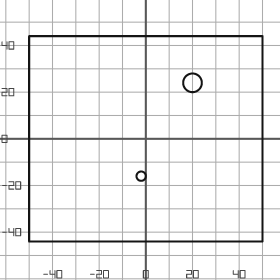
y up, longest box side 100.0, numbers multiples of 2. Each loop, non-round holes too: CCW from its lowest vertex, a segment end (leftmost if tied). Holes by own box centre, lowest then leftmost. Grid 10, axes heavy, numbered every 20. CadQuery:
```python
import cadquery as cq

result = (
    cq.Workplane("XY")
    .moveTo(-50.0, -44.0)
    .lineTo(50.0, -44.0)
    .lineTo(50.0, 44.0)
    .lineTo(-50.0, 44.0)
    .close()
    .moveTo(-2.0, -16.0)
    .circle(2.0)
    .moveTo(20.0, 24.0)
    .circle(4.0)
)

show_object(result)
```